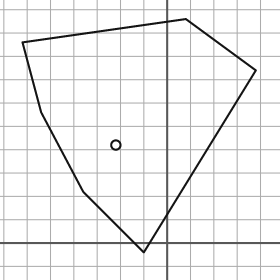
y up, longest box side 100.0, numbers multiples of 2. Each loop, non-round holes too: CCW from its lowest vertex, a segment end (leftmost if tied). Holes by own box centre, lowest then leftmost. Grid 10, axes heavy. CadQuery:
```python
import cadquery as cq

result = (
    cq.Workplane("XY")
    .moveTo(-10.0, -4.0)
    .lineTo(38.0, 74.0)
    .lineTo(8.0, 96.0)
    .lineTo(-62.0, 86.0)
    .lineTo(-54.0, 56.0)
    .lineTo(-36.0, 22.0)
    .close()
    .moveTo(-22.0, 42.0)
    .circle(2.0)
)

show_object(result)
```